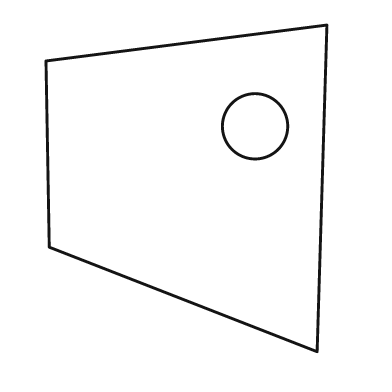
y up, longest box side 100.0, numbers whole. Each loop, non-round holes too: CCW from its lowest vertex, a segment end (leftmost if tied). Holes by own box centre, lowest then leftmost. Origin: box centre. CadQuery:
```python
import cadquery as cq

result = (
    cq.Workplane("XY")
    .moveTo(40.0, -50.0)
    .lineTo(43.0, 50.0)
    .lineTo(-43.0, 39.0)
    .lineTo(-42.0, -18.0)
    .close()
    .moveTo(21.0, 19.0)
    .circle(10.0)
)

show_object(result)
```